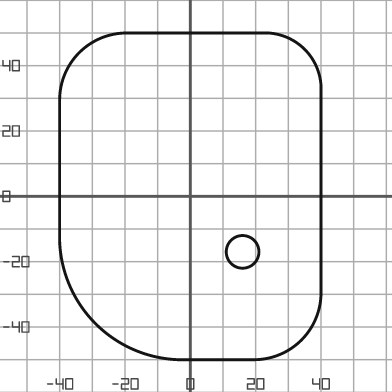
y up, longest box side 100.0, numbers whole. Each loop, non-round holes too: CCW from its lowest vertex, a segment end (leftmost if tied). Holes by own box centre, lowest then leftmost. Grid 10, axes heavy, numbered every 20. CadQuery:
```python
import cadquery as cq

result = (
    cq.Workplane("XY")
    .moveTo(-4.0, -50.0)
    .lineTo(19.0, -50.0)
    .threePointArc((34.0, -44.0), (40.0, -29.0))
    .lineTo(40.0, 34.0)
    .threePointArc((35.0, 45.0), (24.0, 50.0))
    .lineTo(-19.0, 50.0)
    .threePointArc((-34.0, 44.0), (-40.0, 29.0))
    .lineTo(-40.0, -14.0)
    .threePointArc((-29.0, -39.0), (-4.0, -50.0))
    .close()
    .moveTo(16.0, -17.0)
    .circle(5.0)
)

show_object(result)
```